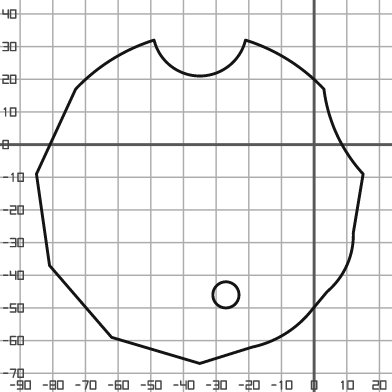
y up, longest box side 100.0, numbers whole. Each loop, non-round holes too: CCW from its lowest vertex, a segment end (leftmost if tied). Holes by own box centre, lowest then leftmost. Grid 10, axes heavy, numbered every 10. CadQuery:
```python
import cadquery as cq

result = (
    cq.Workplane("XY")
    .moveTo(-35.0, -67.0)
    .lineTo(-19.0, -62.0)
    .threePointArc((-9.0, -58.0), (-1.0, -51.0))
    .lineTo(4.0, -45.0)
    .threePointArc((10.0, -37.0), (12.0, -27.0))
    .lineTo(15.0, -9.0)
    .threePointArc((7.0, 3.0), (3.0, 17.0))
    .threePointArc((-8.0, 26.0), (-21.0, 32.0))
    .threePointArc((-35.0, 21.0), (-49.0, 32.0))
    .threePointArc((-62.0, 26.0), (-73.0, 17.0))
    .lineTo(-85.0, -9.0)
    .lineTo(-81.0, -37.0)
    .lineTo(-62.0, -59.0)
    .close()
    .moveTo(-27.0, -46.0)
    .circle(4.0)
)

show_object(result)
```